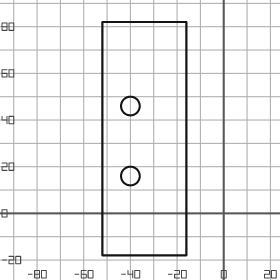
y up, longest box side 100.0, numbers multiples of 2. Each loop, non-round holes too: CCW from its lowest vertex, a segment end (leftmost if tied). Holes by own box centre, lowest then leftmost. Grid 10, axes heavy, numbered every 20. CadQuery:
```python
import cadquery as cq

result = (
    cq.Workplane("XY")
    .moveTo(-52.0, -18.0)
    .lineTo(-16.0, -18.0)
    .lineTo(-16.0, 82.0)
    .lineTo(-52.0, 82.0)
    .close()
    .moveTo(-40.0, 16.0)
    .circle(4.0)
    .moveTo(-40.0, 46.0)
    .circle(4.0)
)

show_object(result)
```